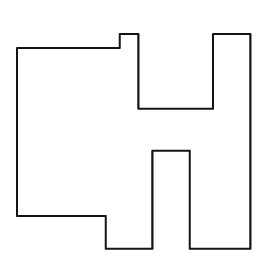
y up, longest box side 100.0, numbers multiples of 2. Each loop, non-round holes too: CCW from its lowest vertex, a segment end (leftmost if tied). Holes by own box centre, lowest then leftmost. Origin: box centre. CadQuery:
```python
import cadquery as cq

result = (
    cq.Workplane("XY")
    .moveTo(-12.0, -46.0)
    .lineTo(8.0, -46.0)
    .lineTo(8.0, -4.0)
    .lineTo(24.0, -4.0)
    .lineTo(24.0, -46.0)
    .lineTo(50.0, -46.0)
    .lineTo(50.0, 46.0)
    .lineTo(34.0, 46.0)
    .lineTo(34.0, 14.0)
    .lineTo(2.0, 14.0)
    .lineTo(2.0, 46.0)
    .lineTo(-6.0, 46.0)
    .lineTo(-6.0, 40.0)
    .lineTo(-50.0, 40.0)
    .lineTo(-50.0, -32.0)
    .lineTo(-12.0, -32.0)
    .close()
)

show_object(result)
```